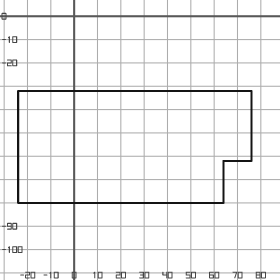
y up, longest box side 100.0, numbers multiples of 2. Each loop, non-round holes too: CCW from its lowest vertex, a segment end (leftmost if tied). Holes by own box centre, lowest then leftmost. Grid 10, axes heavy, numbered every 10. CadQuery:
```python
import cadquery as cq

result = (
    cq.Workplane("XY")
    .moveTo(-24.0, -80.0)
    .lineTo(64.0, -80.0)
    .lineTo(64.0, -62.0)
    .lineTo(76.0, -62.0)
    .lineTo(76.0, -32.0)
    .lineTo(-24.0, -32.0)
    .close()
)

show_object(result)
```